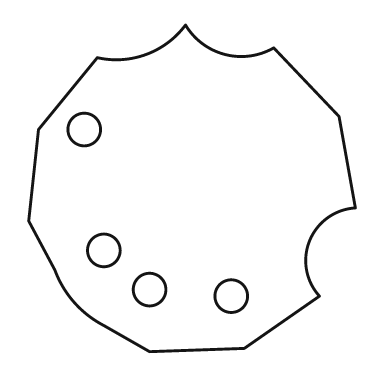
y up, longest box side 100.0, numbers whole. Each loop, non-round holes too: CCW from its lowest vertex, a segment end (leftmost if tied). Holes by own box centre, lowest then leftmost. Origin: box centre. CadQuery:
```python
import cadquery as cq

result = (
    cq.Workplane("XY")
    .moveTo(-13.0, -50.0)
    .lineTo(16.0, -49.0)
    .lineTo(39.0, -33.0)
    .threePointArc((36.0, -16.0), (50.0, -6.0))
    .lineTo(45.0, 22.0)
    .lineTo(25.0, 43.0)
    .threePointArc((10.0, 41.0), (-2.0, 50.0))
    .threePointArc((-14.0, 41.0), (-29.0, 40.0))
    .lineTo(-47.0, 18.0)
    .lineTo(-50.0, -10.0)
    .lineTo(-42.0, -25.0)
    .threePointArc((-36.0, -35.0), (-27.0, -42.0))
    .close()
    .moveTo(12.0, -33.0)
    .circle(5.0)
    .moveTo(-13.0, -31.0)
    .circle(5.0)
    .moveTo(-27.0, -19.0)
    .circle(5.0)
    .moveTo(-33.0, 18.0)
    .circle(5.0)
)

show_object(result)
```